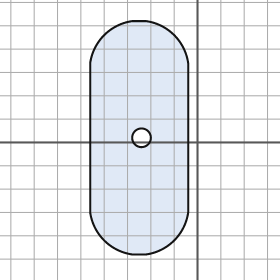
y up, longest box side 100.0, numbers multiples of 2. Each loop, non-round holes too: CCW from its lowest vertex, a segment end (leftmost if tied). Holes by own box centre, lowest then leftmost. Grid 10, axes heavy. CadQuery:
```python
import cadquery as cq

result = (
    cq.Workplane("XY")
    .moveTo(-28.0, -48.0)
    .lineTo(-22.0, -48.0)
    .threePointArc((-10.0, -42.0), (-4.0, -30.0))
    .lineTo(-4.0, 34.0)
    .threePointArc((-10.0, 46.0), (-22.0, 52.0))
    .lineTo(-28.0, 52.0)
    .threePointArc((-40.0, 46.0), (-46.0, 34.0))
    .lineTo(-46.0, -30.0)
    .threePointArc((-40.0, -42.0), (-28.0, -48.0))
    .close()
    .moveTo(-24.0, 2.0)
    .circle(4.0)
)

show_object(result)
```